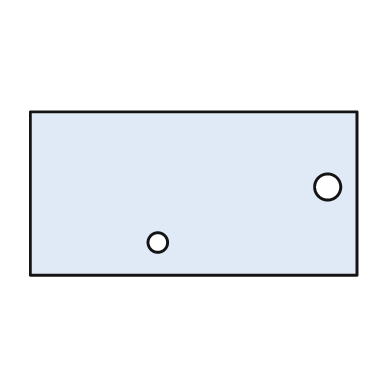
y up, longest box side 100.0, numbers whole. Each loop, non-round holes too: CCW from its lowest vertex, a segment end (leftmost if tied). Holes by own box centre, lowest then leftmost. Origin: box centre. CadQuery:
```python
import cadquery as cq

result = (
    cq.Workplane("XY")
    .moveTo(-50.0, -25.0)
    .lineTo(50.0, -25.0)
    .lineTo(50.0, 25.0)
    .lineTo(-50.0, 25.0)
    .close()
    .moveTo(-11.0, -15.0)
    .circle(3.0)
    .moveTo(41.0, 2.0)
    .circle(4.0)
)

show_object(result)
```